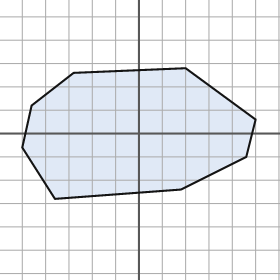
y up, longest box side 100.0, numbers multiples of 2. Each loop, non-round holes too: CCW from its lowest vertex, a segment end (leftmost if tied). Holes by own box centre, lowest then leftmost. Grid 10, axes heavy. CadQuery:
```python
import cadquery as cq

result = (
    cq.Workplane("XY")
    .moveTo(-36.0, -28.0)
    .lineTo(18.0, -24.0)
    .lineTo(46.0, -10.0)
    .lineTo(50.0, 6.0)
    .lineTo(20.0, 28.0)
    .lineTo(-28.0, 26.0)
    .lineTo(-46.0, 12.0)
    .lineTo(-50.0, -6.0)
    .close()
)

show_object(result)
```